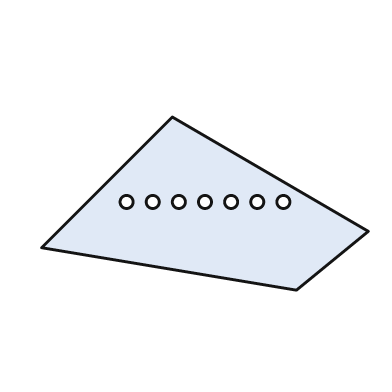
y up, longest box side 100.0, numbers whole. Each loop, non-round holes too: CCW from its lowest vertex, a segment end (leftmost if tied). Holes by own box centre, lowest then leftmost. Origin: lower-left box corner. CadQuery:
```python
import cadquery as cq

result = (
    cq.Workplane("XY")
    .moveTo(78.0, 0.0)
    .lineTo(100.0, 18.0)
    .lineTo(40.0, 53.0)
    .lineTo(0.0, 13.0)
    .close()
    .moveTo(26.0, 27.0)
    .circle(2.0)
    .moveTo(34.0, 27.0)
    .circle(2.0)
    .moveTo(42.0, 27.0)
    .circle(2.0)
    .moveTo(50.0, 27.0)
    .circle(2.0)
    .moveTo(58.0, 27.0)
    .circle(2.0)
    .moveTo(66.0, 27.0)
    .circle(2.0)
    .moveTo(74.0, 27.0)
    .circle(2.0)
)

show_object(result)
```